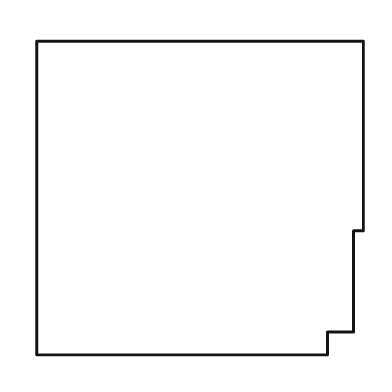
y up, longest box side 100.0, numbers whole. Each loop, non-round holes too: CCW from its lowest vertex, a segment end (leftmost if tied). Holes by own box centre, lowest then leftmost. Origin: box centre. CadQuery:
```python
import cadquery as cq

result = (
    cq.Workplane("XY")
    .moveTo(-50.0, -48.0)
    .lineTo(39.0, -48.0)
    .lineTo(39.0, -41.0)
    .lineTo(47.0, -41.0)
    .lineTo(47.0, -10.0)
    .lineTo(50.0, -10.0)
    .lineTo(50.0, 48.0)
    .lineTo(-50.0, 48.0)
    .close()
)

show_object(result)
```